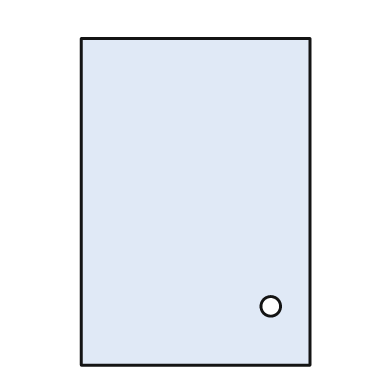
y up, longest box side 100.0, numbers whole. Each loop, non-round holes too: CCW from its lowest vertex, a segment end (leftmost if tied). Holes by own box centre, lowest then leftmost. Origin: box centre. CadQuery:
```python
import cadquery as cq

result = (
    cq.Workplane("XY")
    .moveTo(-35.0, -50.0)
    .lineTo(35.0, -50.0)
    .lineTo(35.0, 50.0)
    .lineTo(-35.0, 50.0)
    .close()
    .moveTo(23.0, -32.0)
    .circle(3.0)
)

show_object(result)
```